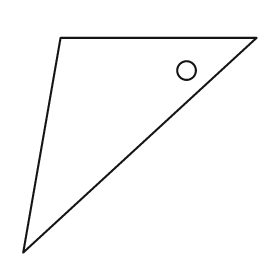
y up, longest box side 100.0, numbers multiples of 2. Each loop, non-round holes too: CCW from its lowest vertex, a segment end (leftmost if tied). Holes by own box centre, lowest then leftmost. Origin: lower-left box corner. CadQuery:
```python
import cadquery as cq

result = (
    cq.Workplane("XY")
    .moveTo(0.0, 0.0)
    .lineTo(100.0, 92.0)
    .lineTo(16.0, 92.0)
    .close()
    .moveTo(70.0, 78.0)
    .circle(4.0)
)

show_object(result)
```